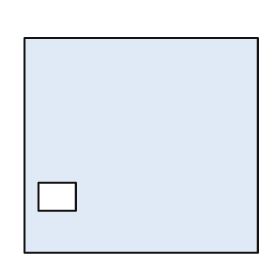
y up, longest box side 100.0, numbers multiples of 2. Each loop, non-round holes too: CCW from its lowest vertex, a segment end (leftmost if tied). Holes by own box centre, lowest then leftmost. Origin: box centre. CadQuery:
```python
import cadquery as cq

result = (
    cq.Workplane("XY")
    .moveTo(-50.0, -46.0)
    .lineTo(50.0, -46.0)
    .lineTo(50.0, 46.0)
    .lineTo(-50.0, 46.0)
    .close()
    .moveTo(-44.0, -28.0)
    .lineTo(-28.0, -28.0)
    .lineTo(-28.0, -16.0)
    .lineTo(-44.0, -16.0)
    .close()
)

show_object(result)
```